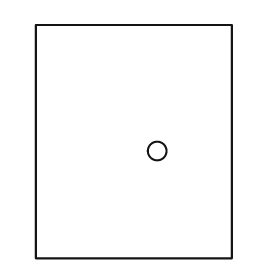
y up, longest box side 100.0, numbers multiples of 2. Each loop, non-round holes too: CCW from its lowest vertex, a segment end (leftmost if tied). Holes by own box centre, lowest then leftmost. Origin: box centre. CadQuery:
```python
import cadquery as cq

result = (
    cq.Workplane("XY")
    .moveTo(-42.0, -50.0)
    .lineTo(42.0, -50.0)
    .lineTo(42.0, 50.0)
    .lineTo(-42.0, 50.0)
    .close()
    .moveTo(10.0, -4.0)
    .circle(4.0)
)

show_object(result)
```